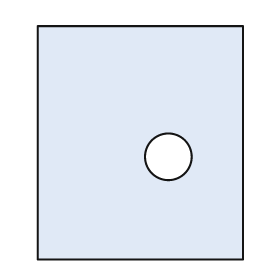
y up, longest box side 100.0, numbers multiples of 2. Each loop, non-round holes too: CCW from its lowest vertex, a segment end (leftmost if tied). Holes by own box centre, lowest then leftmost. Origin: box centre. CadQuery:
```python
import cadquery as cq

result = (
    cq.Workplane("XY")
    .moveTo(-44.0, -50.0)
    .lineTo(44.0, -50.0)
    .lineTo(44.0, 50.0)
    .lineTo(-44.0, 50.0)
    .close()
    .moveTo(12.0, -6.0)
    .circle(10.0)
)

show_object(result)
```